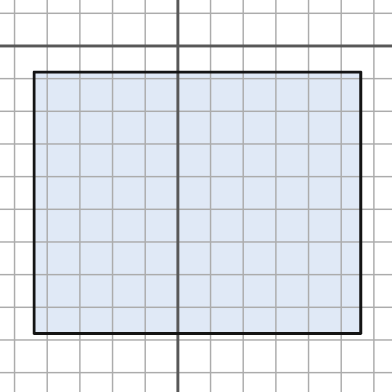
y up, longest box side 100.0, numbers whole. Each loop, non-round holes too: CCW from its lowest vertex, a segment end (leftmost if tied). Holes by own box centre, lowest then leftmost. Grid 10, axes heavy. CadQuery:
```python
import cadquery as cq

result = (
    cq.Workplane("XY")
    .moveTo(-44.0, -88.0)
    .lineTo(56.0, -88.0)
    .lineTo(56.0, -8.0)
    .lineTo(-44.0, -8.0)
    .close()
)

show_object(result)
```